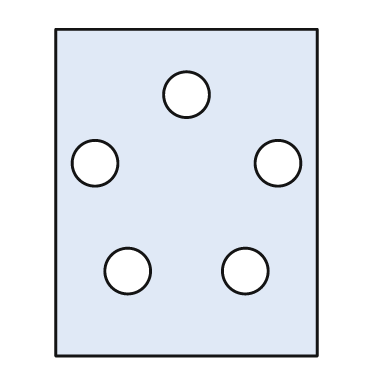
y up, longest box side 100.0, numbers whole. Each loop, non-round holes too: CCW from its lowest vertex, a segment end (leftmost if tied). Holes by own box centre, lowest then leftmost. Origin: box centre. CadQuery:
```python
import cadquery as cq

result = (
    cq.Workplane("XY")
    .moveTo(-40.0, -50.0)
    .lineTo(40.0, -50.0)
    .lineTo(40.0, 50.0)
    .lineTo(-40.0, 50.0)
    .close()
    .moveTo(-18.0, -24.0)
    .circle(7.0)
    .moveTo(18.0, -24.0)
    .circle(7.0)
    .moveTo(-28.0, 9.0)
    .circle(7.0)
    .moveTo(28.0, 9.0)
    .circle(7.0)
    .moveTo(0.0, 30.0)
    .circle(7.0)
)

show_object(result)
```